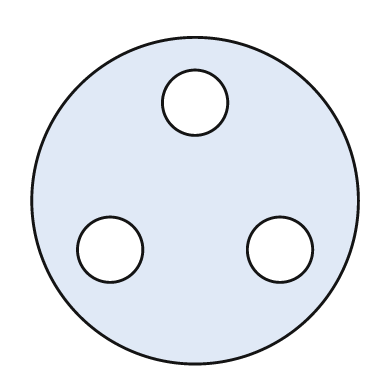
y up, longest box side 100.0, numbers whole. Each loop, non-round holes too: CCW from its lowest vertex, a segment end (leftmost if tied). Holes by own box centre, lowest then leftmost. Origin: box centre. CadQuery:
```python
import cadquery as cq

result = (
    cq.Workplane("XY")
    .moveTo(0.0, 0.0)
    .circle(50.0)
    .moveTo(-26.0, -15.0)
    .circle(10.0)
    .moveTo(26.0, -15.0)
    .circle(10.0)
    .moveTo(0.0, 30.0)
    .circle(10.0)
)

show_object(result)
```